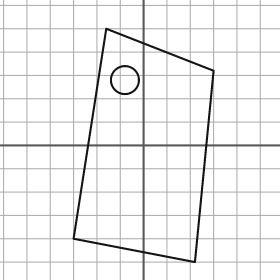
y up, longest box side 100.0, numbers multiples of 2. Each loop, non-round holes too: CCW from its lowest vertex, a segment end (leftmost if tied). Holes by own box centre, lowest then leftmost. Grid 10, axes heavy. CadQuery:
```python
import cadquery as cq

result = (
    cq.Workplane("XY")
    .moveTo(22.0, -50.0)
    .lineTo(30.0, 32.0)
    .lineTo(-16.0, 50.0)
    .lineTo(-30.0, -40.0)
    .close()
    .moveTo(-8.0, 28.0)
    .circle(6.0)
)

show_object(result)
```